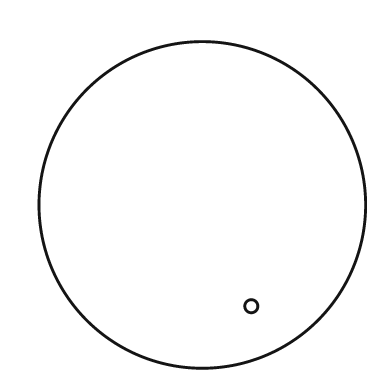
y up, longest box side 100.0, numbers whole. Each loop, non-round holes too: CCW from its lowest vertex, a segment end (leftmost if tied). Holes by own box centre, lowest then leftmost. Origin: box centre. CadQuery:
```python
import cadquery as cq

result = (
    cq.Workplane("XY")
    .moveTo(0.0, 0.0)
    .circle(50.0)
    .moveTo(15.0, -31.0)
    .circle(2.0)
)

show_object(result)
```